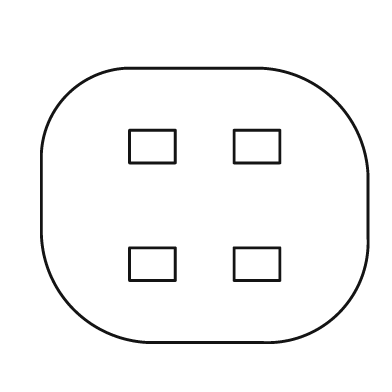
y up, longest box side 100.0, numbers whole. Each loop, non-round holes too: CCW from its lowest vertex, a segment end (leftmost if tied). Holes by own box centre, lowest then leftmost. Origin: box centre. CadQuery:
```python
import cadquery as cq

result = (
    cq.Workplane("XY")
    .moveTo(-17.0, -42.0)
    .lineTo(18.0, -42.0)
    .threePointArc((41.0, -33.0), (50.0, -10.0))
    .lineTo(50.0, 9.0)
    .threePointArc((40.0, 32.0), (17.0, 42.0))
    .lineTo(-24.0, 42.0)
    .threePointArc((-42.0, 34.0), (-50.0, 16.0))
    .lineTo(-50.0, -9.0)
    .threePointArc((-40.0, -32.0), (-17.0, -42.0))
    .close()
    .moveTo(-23.0, -23.0)
    .lineTo(-9.0, -23.0)
    .lineTo(-9.0, -13.0)
    .lineTo(-23.0, -13.0)
    .close()
    .moveTo(9.0, -23.0)
    .lineTo(23.0, -23.0)
    .lineTo(23.0, -13.0)
    .lineTo(9.0, -13.0)
    .close()
    .moveTo(-23.0, 13.0)
    .lineTo(-9.0, 13.0)
    .lineTo(-9.0, 23.0)
    .lineTo(-23.0, 23.0)
    .close()
    .moveTo(9.0, 13.0)
    .lineTo(23.0, 13.0)
    .lineTo(23.0, 23.0)
    .lineTo(9.0, 23.0)
    .close()
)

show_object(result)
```